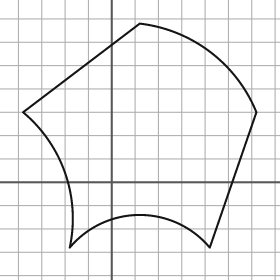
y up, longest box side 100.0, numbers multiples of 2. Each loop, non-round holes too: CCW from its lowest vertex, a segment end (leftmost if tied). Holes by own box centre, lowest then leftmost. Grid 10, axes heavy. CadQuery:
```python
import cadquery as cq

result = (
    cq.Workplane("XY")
    .moveTo(-18.0, -28.0)
    .threePointArc((12.0, -14.0), (42.0, -28.0))
    .lineTo(62.0, 30.0)
    .threePointArc((42.0, 56.0), (12.0, 68.0))
    .lineTo(-38.0, 30.0)
    .threePointArc((-20.0, 4.0), (-18.0, -28.0))
    .close()
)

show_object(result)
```